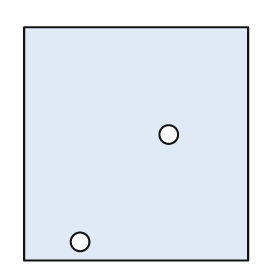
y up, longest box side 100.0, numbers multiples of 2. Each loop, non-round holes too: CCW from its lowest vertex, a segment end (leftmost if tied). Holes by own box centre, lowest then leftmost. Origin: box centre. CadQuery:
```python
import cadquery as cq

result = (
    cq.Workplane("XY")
    .moveTo(-48.0, -50.0)
    .lineTo(48.0, -50.0)
    .lineTo(48.0, 50.0)
    .lineTo(-48.0, 50.0)
    .close()
    .moveTo(-24.0, -42.0)
    .circle(4.0)
    .moveTo(14.0, 4.0)
    .circle(4.0)
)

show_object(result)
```